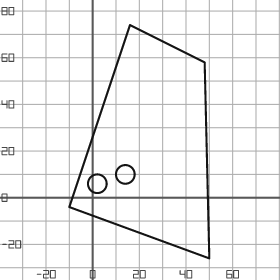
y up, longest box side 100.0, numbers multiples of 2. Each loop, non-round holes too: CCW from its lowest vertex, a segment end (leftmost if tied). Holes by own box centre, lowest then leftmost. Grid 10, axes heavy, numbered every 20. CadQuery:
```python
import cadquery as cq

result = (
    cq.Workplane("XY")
    .moveTo(50.0, -26.0)
    .lineTo(48.0, 58.0)
    .lineTo(16.0, 74.0)
    .lineTo(-10.0, -4.0)
    .close()
    .moveTo(2.0, 6.0)
    .circle(4.0)
    .moveTo(14.0, 10.0)
    .circle(4.0)
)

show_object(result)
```